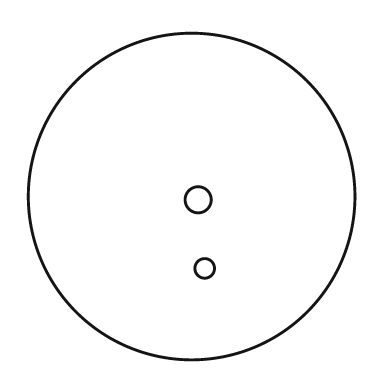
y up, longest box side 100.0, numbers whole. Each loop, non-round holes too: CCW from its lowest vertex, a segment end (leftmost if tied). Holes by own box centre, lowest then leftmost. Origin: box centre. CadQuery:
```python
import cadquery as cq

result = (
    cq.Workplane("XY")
    .moveTo(0.0, 0.0)
    .circle(50.0)
    .moveTo(4.0, -22.0)
    .circle(3.0)
    .moveTo(2.0, -1.0)
    .circle(4.0)
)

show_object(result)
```